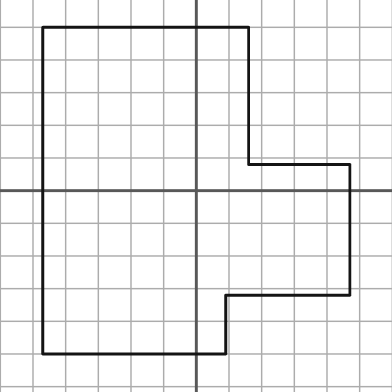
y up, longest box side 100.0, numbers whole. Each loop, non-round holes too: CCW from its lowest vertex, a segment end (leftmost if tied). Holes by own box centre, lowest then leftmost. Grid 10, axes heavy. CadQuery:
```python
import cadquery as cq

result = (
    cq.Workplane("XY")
    .moveTo(-47.0, -50.0)
    .lineTo(9.0, -50.0)
    .lineTo(9.0, -32.0)
    .lineTo(47.0, -32.0)
    .lineTo(47.0, 8.0)
    .lineTo(16.0, 8.0)
    .lineTo(16.0, 50.0)
    .lineTo(-47.0, 50.0)
    .close()
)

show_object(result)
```